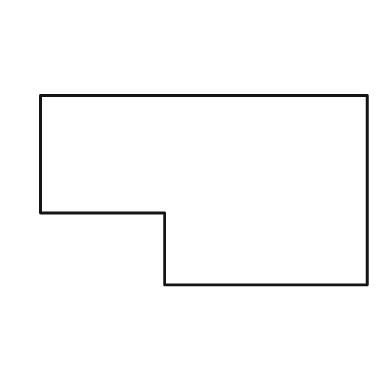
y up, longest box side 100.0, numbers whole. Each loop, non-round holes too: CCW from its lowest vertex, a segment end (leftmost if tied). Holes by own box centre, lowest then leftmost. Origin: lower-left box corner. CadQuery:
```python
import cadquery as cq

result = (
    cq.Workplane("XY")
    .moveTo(38.0, 0.0)
    .lineTo(100.0, 0.0)
    .lineTo(100.0, 58.0)
    .lineTo(0.0, 58.0)
    .lineTo(0.0, 22.0)
    .lineTo(38.0, 22.0)
    .close()
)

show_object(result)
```